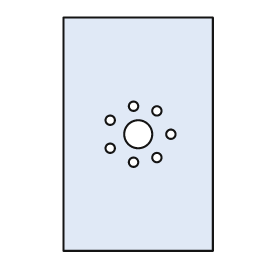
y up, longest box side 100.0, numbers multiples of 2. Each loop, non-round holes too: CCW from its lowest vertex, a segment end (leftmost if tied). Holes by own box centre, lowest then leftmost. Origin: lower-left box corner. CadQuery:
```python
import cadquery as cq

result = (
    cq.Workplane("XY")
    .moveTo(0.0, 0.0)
    .lineTo(64.0, 0.0)
    .lineTo(64.0, 100.0)
    .lineTo(0.0, 100.0)
    .close()
    .moveTo(30.0, 38.0)
    .circle(2.0)
    .moveTo(40.0, 40.0)
    .circle(2.0)
    .moveTo(20.0, 44.0)
    .circle(2.0)
    .moveTo(32.0, 50.0)
    .circle(6.0)
    .moveTo(46.0, 50.0)
    .circle(2.0)
    .moveTo(20.0, 56.0)
    .circle(2.0)
    .moveTo(40.0, 60.0)
    .circle(2.0)
    .moveTo(30.0, 62.0)
    .circle(2.0)
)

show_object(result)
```